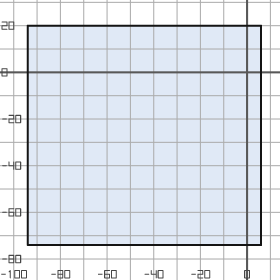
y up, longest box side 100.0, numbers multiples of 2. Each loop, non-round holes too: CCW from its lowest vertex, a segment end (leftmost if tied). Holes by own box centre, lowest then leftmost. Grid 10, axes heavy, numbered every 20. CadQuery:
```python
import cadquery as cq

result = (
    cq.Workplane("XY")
    .moveTo(-94.0, -74.0)
    .lineTo(6.0, -74.0)
    .lineTo(6.0, 20.0)
    .lineTo(-94.0, 20.0)
    .close()
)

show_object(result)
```